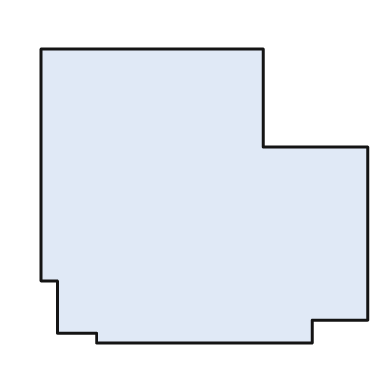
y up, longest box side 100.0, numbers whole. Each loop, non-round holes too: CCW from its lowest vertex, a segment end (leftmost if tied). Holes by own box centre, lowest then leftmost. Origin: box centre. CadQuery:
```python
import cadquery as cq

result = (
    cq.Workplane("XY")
    .moveTo(-33.0, -45.0)
    .lineTo(33.0, -45.0)
    .lineTo(33.0, -38.0)
    .lineTo(50.0, -38.0)
    .lineTo(50.0, 15.0)
    .lineTo(18.0, 15.0)
    .lineTo(18.0, 45.0)
    .lineTo(-50.0, 45.0)
    .lineTo(-50.0, -26.0)
    .lineTo(-45.0, -26.0)
    .lineTo(-45.0, -42.0)
    .lineTo(-33.0, -42.0)
    .close()
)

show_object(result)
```